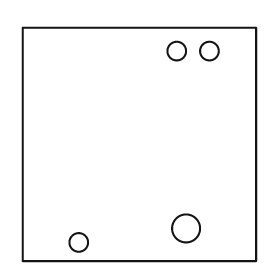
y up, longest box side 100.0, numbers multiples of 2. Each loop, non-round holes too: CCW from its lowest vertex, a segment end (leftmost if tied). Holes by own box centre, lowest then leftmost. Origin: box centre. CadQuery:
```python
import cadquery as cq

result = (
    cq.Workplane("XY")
    .moveTo(-50.0, -50.0)
    .lineTo(50.0, -50.0)
    .lineTo(50.0, 50.0)
    .lineTo(-50.0, 50.0)
    .close()
    .moveTo(-26.0, -42.0)
    .circle(4.0)
    .moveTo(20.0, -36.0)
    .circle(6.0)
    .moveTo(16.0, 40.0)
    .circle(4.0)
    .moveTo(30.0, 40.0)
    .circle(4.0)
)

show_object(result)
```